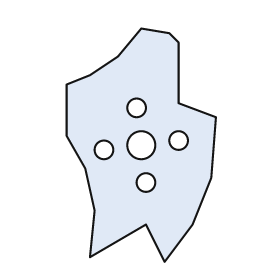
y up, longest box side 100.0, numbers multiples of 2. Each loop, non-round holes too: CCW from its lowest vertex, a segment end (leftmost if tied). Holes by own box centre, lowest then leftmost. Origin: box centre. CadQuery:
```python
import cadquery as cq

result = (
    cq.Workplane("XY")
    .moveTo(10.0, -50.0)
    .lineTo(22.0, -34.0)
    .lineTo(30.0, -14.0)
    .lineTo(32.0, 12.0)
    .lineTo(16.0, 18.0)
    .lineTo(16.0, 44.0)
    .lineTo(12.0, 48.0)
    .lineTo(0.0, 50.0)
    .lineTo(-10.0, 38.0)
    .lineTo(-22.0, 30.0)
    .lineTo(-32.0, 26.0)
    .lineTo(-32.0, 4.0)
    .lineTo(-24.0, -10.0)
    .lineTo(-20.0, -28.0)
    .lineTo(-22.0, -48.0)
    .lineTo(2.0, -34.0)
    .close()
    .moveTo(2.0, -16.0)
    .circle(4.0)
    .moveTo(-16.0, -2.0)
    .circle(4.0)
    .moveTo(0.0, 0.0)
    .circle(6.0)
    .moveTo(16.0, 2.0)
    .circle(4.0)
    .moveTo(-2.0, 16.0)
    .circle(4.0)
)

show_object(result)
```